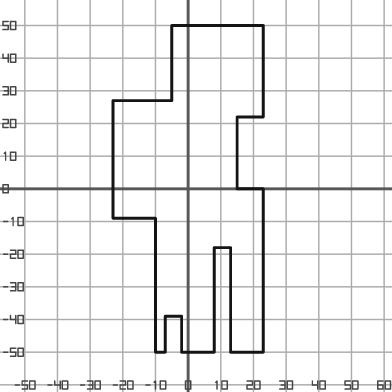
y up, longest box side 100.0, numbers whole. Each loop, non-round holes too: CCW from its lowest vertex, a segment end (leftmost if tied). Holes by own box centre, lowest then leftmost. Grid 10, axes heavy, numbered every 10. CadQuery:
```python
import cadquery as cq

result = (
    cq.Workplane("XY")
    .moveTo(-10.0, -50.0)
    .lineTo(-7.0, -50.0)
    .lineTo(-7.0, -39.0)
    .lineTo(-2.0, -39.0)
    .lineTo(-2.0, -50.0)
    .lineTo(8.0, -50.0)
    .lineTo(8.0, -18.0)
    .lineTo(13.0, -18.0)
    .lineTo(13.0, -50.0)
    .lineTo(23.0, -50.0)
    .lineTo(23.0, 0.0)
    .lineTo(15.0, 0.0)
    .lineTo(15.0, 22.0)
    .lineTo(23.0, 22.0)
    .lineTo(23.0, 50.0)
    .lineTo(-5.0, 50.0)
    .lineTo(-5.0, 27.0)
    .lineTo(-23.0, 27.0)
    .lineTo(-23.0, -9.0)
    .lineTo(-10.0, -9.0)
    .close()
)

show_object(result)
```